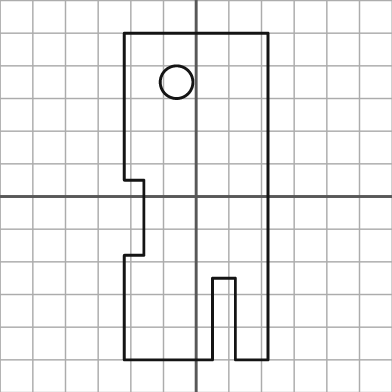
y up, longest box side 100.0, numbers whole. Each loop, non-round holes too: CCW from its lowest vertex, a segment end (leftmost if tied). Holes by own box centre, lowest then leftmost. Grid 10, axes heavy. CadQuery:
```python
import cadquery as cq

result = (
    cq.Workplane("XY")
    .moveTo(-22.0, -50.0)
    .lineTo(5.0, -50.0)
    .lineTo(5.0, -25.0)
    .lineTo(12.0, -25.0)
    .lineTo(12.0, -50.0)
    .lineTo(22.0, -50.0)
    .lineTo(22.0, 50.0)
    .lineTo(-22.0, 50.0)
    .lineTo(-22.0, 5.0)
    .lineTo(-16.0, 5.0)
    .lineTo(-16.0, -18.0)
    .lineTo(-22.0, -18.0)
    .close()
    .moveTo(-6.0, 35.0)
    .circle(5.0)
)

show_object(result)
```